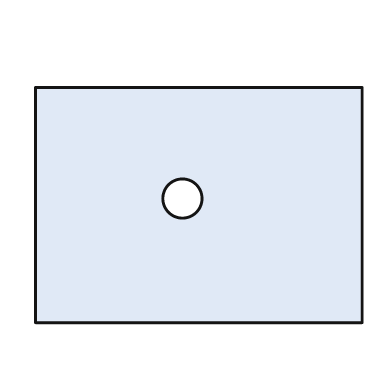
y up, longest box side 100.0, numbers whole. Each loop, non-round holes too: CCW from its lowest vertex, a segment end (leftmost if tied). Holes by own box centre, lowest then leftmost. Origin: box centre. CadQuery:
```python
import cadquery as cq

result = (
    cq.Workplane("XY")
    .moveTo(-50.0, -36.0)
    .lineTo(50.0, -36.0)
    .lineTo(50.0, 36.0)
    .lineTo(-50.0, 36.0)
    .close()
    .moveTo(-5.0, 2.0)
    .circle(6.0)
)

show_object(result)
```